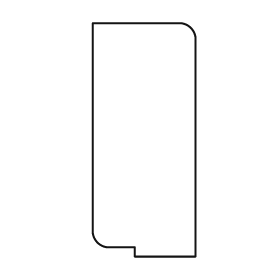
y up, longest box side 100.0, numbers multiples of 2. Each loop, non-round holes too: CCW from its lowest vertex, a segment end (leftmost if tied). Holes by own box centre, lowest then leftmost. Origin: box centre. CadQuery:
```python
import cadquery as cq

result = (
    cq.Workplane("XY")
    .moveTo(-4.0, -50.0)
    .lineTo(22.0, -50.0)
    .lineTo(22.0, 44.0)
    .threePointArc((20.0, 48.0), (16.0, 50.0))
    .lineTo(-22.0, 50.0)
    .lineTo(-22.0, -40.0)
    .threePointArc((-20.0, -44.0), (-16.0, -46.0))
    .lineTo(-4.0, -46.0)
    .close()
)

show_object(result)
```